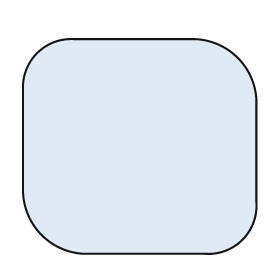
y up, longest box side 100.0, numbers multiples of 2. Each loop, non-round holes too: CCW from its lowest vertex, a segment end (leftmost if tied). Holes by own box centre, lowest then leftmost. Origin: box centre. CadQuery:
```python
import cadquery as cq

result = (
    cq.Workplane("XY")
    .moveTo(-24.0, -46.0)
    .lineTo(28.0, -46.0)
    .threePointArc((44.0, -40.0), (50.0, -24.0))
    .lineTo(50.0, 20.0)
    .threePointArc((42.0, 38.0), (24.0, 46.0))
    .lineTo(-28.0, 46.0)
    .threePointArc((-44.0, 40.0), (-50.0, 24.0))
    .lineTo(-50.0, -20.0)
    .threePointArc((-42.0, -38.0), (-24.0, -46.0))
    .close()
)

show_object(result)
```